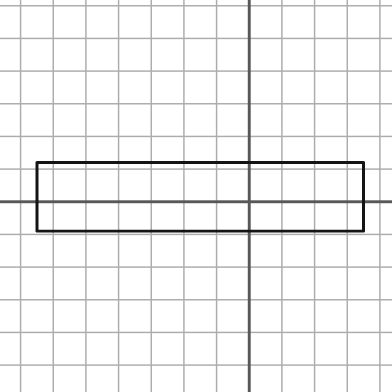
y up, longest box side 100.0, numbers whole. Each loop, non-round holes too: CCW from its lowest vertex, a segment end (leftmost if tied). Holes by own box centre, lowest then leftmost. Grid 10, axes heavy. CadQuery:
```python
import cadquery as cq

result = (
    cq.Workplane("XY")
    .moveTo(-65.0, -9.0)
    .lineTo(35.0, -9.0)
    .lineTo(35.0, 12.0)
    .lineTo(-65.0, 12.0)
    .close()
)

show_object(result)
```